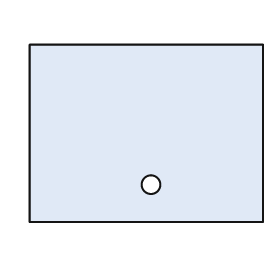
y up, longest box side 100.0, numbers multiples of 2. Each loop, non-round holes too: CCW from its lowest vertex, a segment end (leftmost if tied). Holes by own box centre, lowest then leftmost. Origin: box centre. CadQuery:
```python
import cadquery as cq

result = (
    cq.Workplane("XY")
    .moveTo(-50.0, -38.0)
    .lineTo(50.0, -38.0)
    .lineTo(50.0, 38.0)
    .lineTo(-50.0, 38.0)
    .close()
    .moveTo(2.0, -22.0)
    .circle(4.0)
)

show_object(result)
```